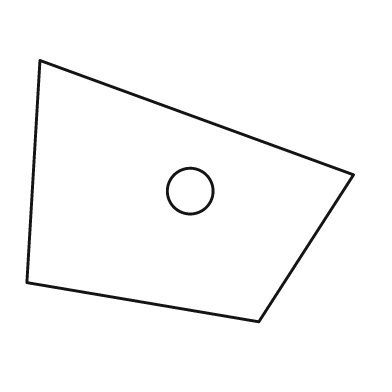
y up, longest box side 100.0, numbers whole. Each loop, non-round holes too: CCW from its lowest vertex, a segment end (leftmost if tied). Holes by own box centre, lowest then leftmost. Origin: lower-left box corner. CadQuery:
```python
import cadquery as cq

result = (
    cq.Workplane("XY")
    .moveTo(71.0, 0.0)
    .lineTo(100.0, 45.0)
    .lineTo(4.0, 80.0)
    .lineTo(0.0, 12.0)
    .close()
    .moveTo(50.0, 40.0)
    .circle(7.0)
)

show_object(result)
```